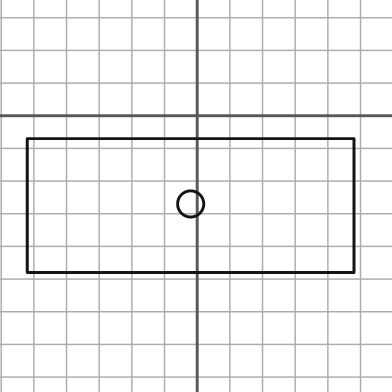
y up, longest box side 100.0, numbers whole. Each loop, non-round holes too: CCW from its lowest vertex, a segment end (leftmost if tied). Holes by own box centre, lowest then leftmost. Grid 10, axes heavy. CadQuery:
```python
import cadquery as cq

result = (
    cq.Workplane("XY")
    .moveTo(-52.0, -48.0)
    .lineTo(48.0, -48.0)
    .lineTo(48.0, -7.0)
    .lineTo(-52.0, -7.0)
    .close()
    .moveTo(-2.0, -27.0)
    .circle(4.0)
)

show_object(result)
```